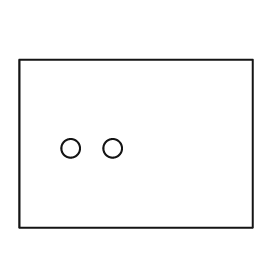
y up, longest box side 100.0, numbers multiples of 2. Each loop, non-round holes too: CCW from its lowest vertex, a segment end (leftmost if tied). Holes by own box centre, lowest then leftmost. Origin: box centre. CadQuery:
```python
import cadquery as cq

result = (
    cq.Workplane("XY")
    .moveTo(-50.0, -36.0)
    .lineTo(50.0, -36.0)
    .lineTo(50.0, 36.0)
    .lineTo(-50.0, 36.0)
    .close()
    .moveTo(-28.0, -2.0)
    .circle(4.0)
    .moveTo(-10.0, -2.0)
    .circle(4.0)
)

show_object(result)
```